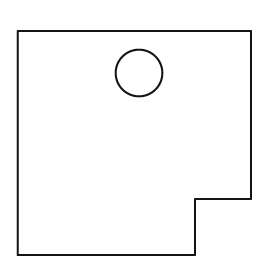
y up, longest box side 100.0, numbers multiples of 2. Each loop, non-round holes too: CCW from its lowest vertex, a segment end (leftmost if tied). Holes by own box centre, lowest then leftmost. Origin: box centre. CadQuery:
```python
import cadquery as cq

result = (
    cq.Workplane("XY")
    .moveTo(-50.0, -48.0)
    .lineTo(26.0, -48.0)
    .lineTo(26.0, -24.0)
    .lineTo(50.0, -24.0)
    .lineTo(50.0, 48.0)
    .lineTo(-50.0, 48.0)
    .close()
    .moveTo(2.0, 30.0)
    .circle(10.0)
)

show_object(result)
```